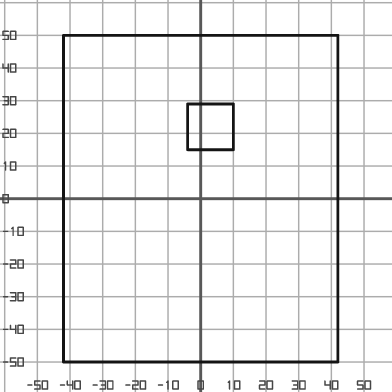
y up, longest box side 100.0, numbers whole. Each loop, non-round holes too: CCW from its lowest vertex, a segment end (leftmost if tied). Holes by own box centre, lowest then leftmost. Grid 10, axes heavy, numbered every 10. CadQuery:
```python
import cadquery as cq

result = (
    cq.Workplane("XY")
    .moveTo(-42.0, -50.0)
    .lineTo(42.0, -50.0)
    .lineTo(42.0, 50.0)
    .lineTo(-42.0, 50.0)
    .close()
    .moveTo(-4.0, 15.0)
    .lineTo(10.0, 15.0)
    .lineTo(10.0, 29.0)
    .lineTo(-4.0, 29.0)
    .close()
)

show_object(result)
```